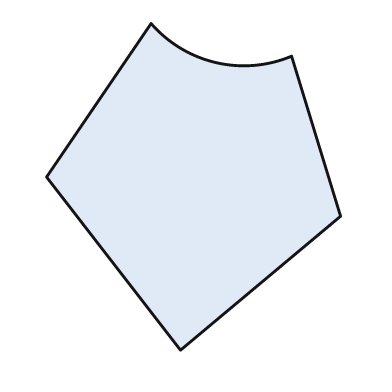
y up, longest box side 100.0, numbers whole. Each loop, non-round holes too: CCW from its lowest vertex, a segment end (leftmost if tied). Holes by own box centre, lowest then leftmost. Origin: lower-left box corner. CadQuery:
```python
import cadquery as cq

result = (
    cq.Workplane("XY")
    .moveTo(41.0, 0.0)
    .lineTo(90.0, 41.0)
    .lineTo(75.0, 90.0)
    .threePointArc((52.0, 88.0), (32.0, 100.0))
    .lineTo(0.0, 53.0)
    .close()
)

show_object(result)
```